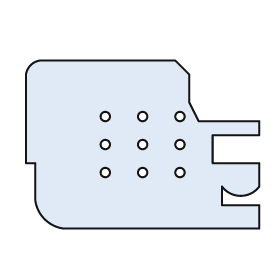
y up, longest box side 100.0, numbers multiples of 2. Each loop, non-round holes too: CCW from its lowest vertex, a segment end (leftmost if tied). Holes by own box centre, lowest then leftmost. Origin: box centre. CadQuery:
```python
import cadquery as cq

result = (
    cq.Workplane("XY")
    .moveTo(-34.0, -36.0)
    .lineTo(50.0, -36.0)
    .lineTo(50.0, -26.0)
    .lineTo(34.0, -26.0)
    .lineTo(34.0, -18.0)
    .threePointArc((42.0, -22.0), (50.0, -18.0))
    .lineTo(50.0, -8.0)
    .lineTo(30.0, -8.0)
    .lineTo(30.0, 4.0)
    .lineTo(50.0, 4.0)
    .lineTo(50.0, 10.0)
    .lineTo(24.0, 10.0)
    .lineTo(20.0, 18.0)
    .lineTo(20.0, 30.0)
    .lineTo(14.0, 36.0)
    .lineTo(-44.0, 36.0)
    .threePointArc((-48.0, 34.0), (-50.0, 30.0))
    .lineTo(-50.0, -8.0)
    .lineTo(-46.0, -8.0)
    .lineTo(-46.0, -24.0)
    .threePointArc((-42.0, -32.0), (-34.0, -36.0))
    .close()
    .moveTo(-16.0, -12.0)
    .circle(2.0)
    .moveTo(0.0, -12.0)
    .circle(2.0)
    .moveTo(16.0, -12.0)
    .circle(2.0)
    .moveTo(-16.0, 0.0)
    .circle(2.0)
    .moveTo(0.0, 0.0)
    .circle(2.0)
    .moveTo(16.0, 0.0)
    .circle(2.0)
    .moveTo(-16.0, 12.0)
    .circle(2.0)
    .moveTo(0.0, 12.0)
    .circle(2.0)
    .moveTo(16.0, 12.0)
    .circle(2.0)
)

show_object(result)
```